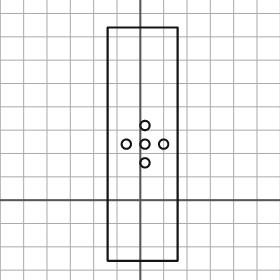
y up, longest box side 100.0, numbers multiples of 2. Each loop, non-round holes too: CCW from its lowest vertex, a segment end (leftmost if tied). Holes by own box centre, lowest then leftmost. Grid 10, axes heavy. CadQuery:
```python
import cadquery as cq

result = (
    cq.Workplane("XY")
    .moveTo(-14.0, -26.0)
    .lineTo(16.0, -26.0)
    .lineTo(16.0, 74.0)
    .lineTo(-14.0, 74.0)
    .close()
    .moveTo(2.0, 16.0)
    .circle(2.0)
    .moveTo(-6.0, 24.0)
    .circle(2.0)
    .moveTo(2.0, 24.0)
    .circle(2.0)
    .moveTo(10.0, 24.0)
    .circle(2.0)
    .moveTo(2.0, 32.0)
    .circle(2.0)
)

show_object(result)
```